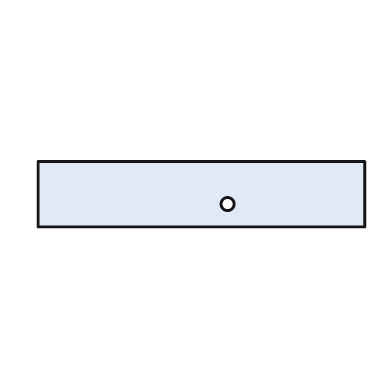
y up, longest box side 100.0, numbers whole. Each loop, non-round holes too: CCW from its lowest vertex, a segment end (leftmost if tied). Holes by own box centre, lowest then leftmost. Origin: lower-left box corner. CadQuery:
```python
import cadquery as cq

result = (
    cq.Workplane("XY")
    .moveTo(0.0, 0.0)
    .lineTo(100.0, 0.0)
    .lineTo(100.0, 20.0)
    .lineTo(0.0, 20.0)
    .close()
    .moveTo(58.0, 7.0)
    .circle(2.0)
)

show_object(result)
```